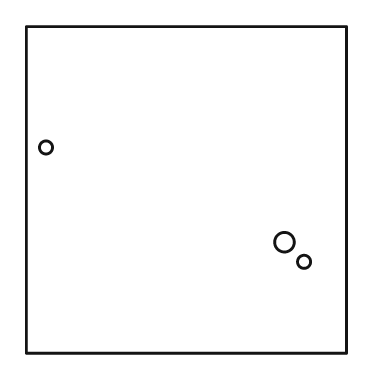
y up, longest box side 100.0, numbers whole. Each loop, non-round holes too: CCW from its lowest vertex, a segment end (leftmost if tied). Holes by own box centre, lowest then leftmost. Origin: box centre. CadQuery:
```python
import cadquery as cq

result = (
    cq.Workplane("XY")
    .moveTo(-49.0, -50.0)
    .lineTo(49.0, -50.0)
    .lineTo(49.0, 50.0)
    .lineTo(-49.0, 50.0)
    .close()
    .moveTo(36.0, -22.0)
    .circle(2.0)
    .moveTo(30.0, -16.0)
    .circle(3.0)
    .moveTo(-43.0, 13.0)
    .circle(2.0)
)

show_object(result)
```